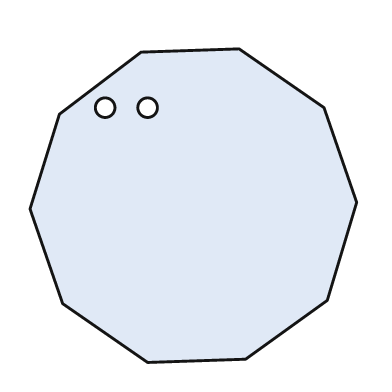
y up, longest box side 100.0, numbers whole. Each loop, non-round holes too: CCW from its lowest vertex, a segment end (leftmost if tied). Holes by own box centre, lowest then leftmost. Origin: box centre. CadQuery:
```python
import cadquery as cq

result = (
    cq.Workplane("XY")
    .moveTo(-14.0, -48.0)
    .lineTo(16.0, -47.0)
    .lineTo(41.0, -29.0)
    .lineTo(50.0, 1.0)
    .lineTo(40.0, 30.0)
    .lineTo(14.0, 48.0)
    .lineTo(-16.0, 47.0)
    .lineTo(-41.0, 28.0)
    .lineTo(-50.0, -1.0)
    .lineTo(-40.0, -30.0)
    .close()
    .moveTo(-27.0, 30.0)
    .circle(3.0)
    .moveTo(-14.0, 30.0)
    .circle(3.0)
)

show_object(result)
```